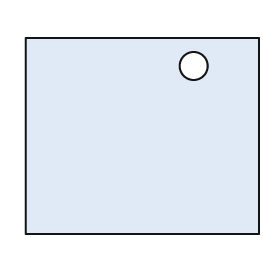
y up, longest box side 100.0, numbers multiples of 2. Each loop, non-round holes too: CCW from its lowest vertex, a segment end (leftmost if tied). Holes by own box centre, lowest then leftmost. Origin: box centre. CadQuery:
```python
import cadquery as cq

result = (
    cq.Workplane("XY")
    .moveTo(-50.0, -42.0)
    .lineTo(50.0, -42.0)
    .lineTo(50.0, 42.0)
    .lineTo(-50.0, 42.0)
    .close()
    .moveTo(22.0, 30.0)
    .circle(6.0)
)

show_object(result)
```